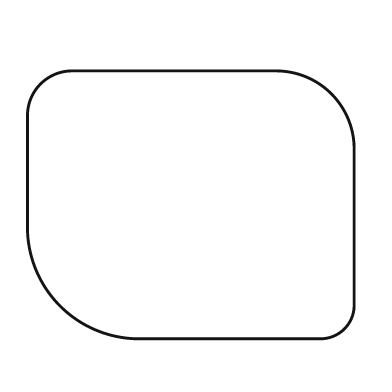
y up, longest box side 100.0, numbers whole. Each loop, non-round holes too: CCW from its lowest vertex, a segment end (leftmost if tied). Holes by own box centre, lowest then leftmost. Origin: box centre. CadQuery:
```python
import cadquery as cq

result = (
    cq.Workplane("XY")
    .moveTo(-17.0, -41.0)
    .lineTo(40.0, -41.0)
    .threePointArc((47.0, -38.0), (50.0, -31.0))
    .lineTo(50.0, 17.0)
    .threePointArc((43.0, 34.0), (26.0, 41.0))
    .lineTo(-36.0, 41.0)
    .threePointArc((-46.0, 37.0), (-50.0, 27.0))
    .lineTo(-50.0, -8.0)
    .threePointArc((-40.0, -31.0), (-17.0, -41.0))
    .close()
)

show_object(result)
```